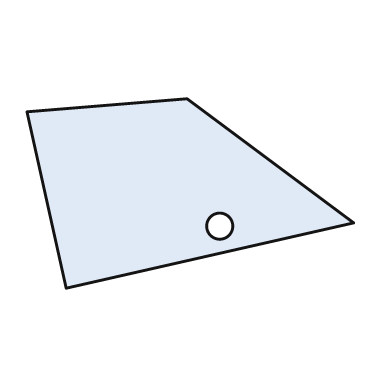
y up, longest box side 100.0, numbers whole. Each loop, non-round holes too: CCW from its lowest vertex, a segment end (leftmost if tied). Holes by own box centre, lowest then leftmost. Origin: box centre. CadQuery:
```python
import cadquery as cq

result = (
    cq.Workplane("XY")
    .moveTo(-38.0, -29.0)
    .lineTo(50.0, -9.0)
    .lineTo(-1.0, 29.0)
    .lineTo(-50.0, 25.0)
    .close()
    .moveTo(9.0, -10.0)
    .circle(4.0)
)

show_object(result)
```